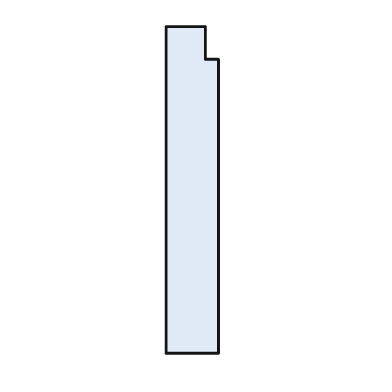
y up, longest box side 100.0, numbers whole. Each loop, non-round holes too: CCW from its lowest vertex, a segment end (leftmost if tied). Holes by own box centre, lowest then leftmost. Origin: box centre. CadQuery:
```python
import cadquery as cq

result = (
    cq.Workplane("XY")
    .moveTo(-8.0, -50.0)
    .lineTo(8.0, -50.0)
    .lineTo(8.0, 40.0)
    .lineTo(4.0, 40.0)
    .lineTo(4.0, 50.0)
    .lineTo(-8.0, 50.0)
    .close()
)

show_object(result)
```